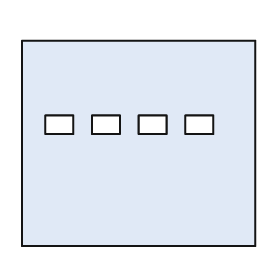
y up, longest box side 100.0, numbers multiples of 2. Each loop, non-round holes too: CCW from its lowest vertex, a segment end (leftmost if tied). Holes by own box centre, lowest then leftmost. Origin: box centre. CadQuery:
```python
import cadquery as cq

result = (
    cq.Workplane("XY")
    .moveTo(-50.0, -44.0)
    .lineTo(50.0, -44.0)
    .lineTo(50.0, 44.0)
    .lineTo(-50.0, 44.0)
    .close()
    .moveTo(-40.0, 4.0)
    .lineTo(-28.0, 4.0)
    .lineTo(-28.0, 12.0)
    .lineTo(-40.0, 12.0)
    .close()
    .moveTo(-20.0, 4.0)
    .lineTo(-8.0, 4.0)
    .lineTo(-8.0, 12.0)
    .lineTo(-20.0, 12.0)
    .close()
    .moveTo(0.0, 4.0)
    .lineTo(12.0, 4.0)
    .lineTo(12.0, 12.0)
    .lineTo(0.0, 12.0)
    .close()
    .moveTo(20.0, 4.0)
    .lineTo(32.0, 4.0)
    .lineTo(32.0, 12.0)
    .lineTo(20.0, 12.0)
    .close()
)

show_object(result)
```